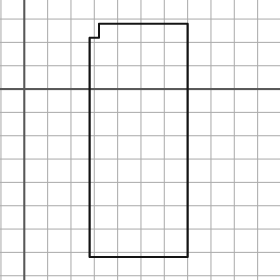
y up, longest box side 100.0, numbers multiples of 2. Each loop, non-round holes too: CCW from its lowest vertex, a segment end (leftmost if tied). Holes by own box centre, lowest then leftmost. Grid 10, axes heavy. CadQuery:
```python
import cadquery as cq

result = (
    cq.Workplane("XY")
    .moveTo(28.0, -72.0)
    .lineTo(70.0, -72.0)
    .lineTo(70.0, 28.0)
    .lineTo(32.0, 28.0)
    .lineTo(32.0, 22.0)
    .lineTo(28.0, 22.0)
    .close()
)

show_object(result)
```